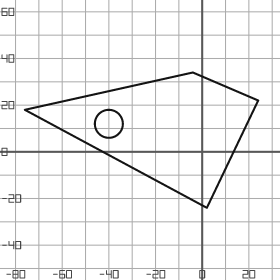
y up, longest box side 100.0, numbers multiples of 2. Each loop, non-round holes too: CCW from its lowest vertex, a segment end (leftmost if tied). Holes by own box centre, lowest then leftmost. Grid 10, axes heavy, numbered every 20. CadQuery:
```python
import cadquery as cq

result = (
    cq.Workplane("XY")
    .moveTo(2.0, -24.0)
    .lineTo(24.0, 22.0)
    .lineTo(-4.0, 34.0)
    .lineTo(-76.0, 18.0)
    .close()
    .moveTo(-40.0, 12.0)
    .circle(6.0)
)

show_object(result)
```